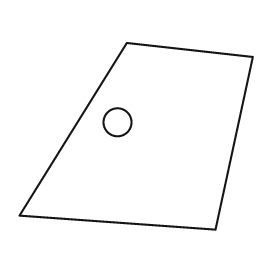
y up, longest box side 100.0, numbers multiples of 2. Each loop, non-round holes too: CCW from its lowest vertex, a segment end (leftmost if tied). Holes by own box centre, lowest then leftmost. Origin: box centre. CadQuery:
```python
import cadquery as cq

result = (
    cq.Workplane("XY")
    .moveTo(34.0, -40.0)
    .lineTo(50.0, 34.0)
    .lineTo(-4.0, 40.0)
    .lineTo(-50.0, -34.0)
    .close()
    .moveTo(-8.0, 6.0)
    .circle(6.0)
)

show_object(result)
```